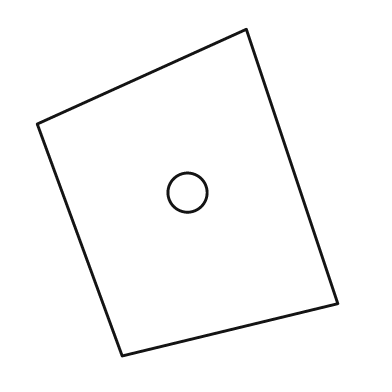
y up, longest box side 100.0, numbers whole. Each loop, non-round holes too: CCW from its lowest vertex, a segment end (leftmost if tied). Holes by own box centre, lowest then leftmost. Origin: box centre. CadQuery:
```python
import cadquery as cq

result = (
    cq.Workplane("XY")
    .moveTo(-20.0, -50.0)
    .lineTo(46.0, -34.0)
    .lineTo(18.0, 50.0)
    .lineTo(-46.0, 21.0)
    .close()
    .moveTo(0.0, 0.0)
    .circle(6.0)
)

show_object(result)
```